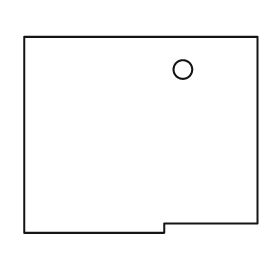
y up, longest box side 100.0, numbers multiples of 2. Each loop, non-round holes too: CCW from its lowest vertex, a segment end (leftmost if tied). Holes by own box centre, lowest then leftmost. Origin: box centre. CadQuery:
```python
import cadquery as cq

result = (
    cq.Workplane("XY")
    .moveTo(-50.0, -42.0)
    .lineTo(10.0, -42.0)
    .lineTo(10.0, -38.0)
    .lineTo(50.0, -38.0)
    .lineTo(50.0, 42.0)
    .lineTo(-50.0, 42.0)
    .close()
    .moveTo(18.0, 28.0)
    .circle(4.0)
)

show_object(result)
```